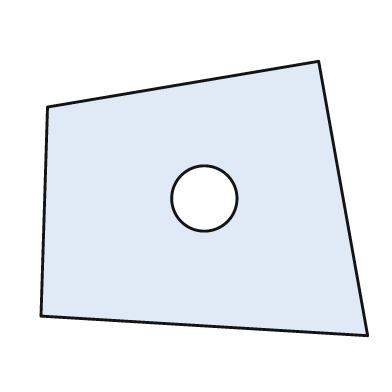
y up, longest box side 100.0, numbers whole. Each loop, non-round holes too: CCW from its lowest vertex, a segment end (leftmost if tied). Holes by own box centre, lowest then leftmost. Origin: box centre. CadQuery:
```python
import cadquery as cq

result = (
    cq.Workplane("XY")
    .moveTo(50.0, -42.0)
    .lineTo(35.0, 42.0)
    .lineTo(-48.0, 28.0)
    .lineTo(-50.0, -36.0)
    .close()
    .moveTo(0.0, 0.0)
    .circle(10.0)
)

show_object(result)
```